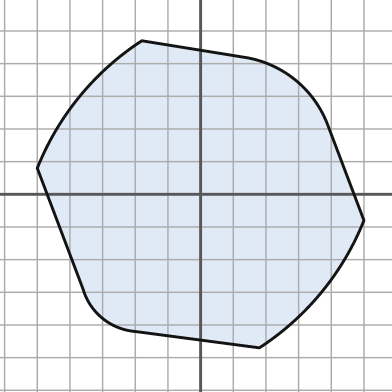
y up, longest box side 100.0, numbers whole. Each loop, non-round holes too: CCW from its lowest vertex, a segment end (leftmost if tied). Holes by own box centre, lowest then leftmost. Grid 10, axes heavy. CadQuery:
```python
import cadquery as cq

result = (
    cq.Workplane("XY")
    .moveTo(18.0, -47.0)
    .threePointArc((37.0, -30.0), (50.0, -8.0))
    .lineTo(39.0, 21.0)
    .threePointArc((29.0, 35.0), (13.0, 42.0))
    .lineTo(-18.0, 47.0)
    .threePointArc((-37.0, 30.0), (-50.0, 8.0))
    .lineTo(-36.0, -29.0)
    .threePointArc((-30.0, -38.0), (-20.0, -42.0))
    .close()
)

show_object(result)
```